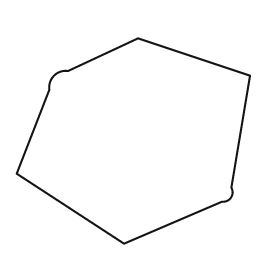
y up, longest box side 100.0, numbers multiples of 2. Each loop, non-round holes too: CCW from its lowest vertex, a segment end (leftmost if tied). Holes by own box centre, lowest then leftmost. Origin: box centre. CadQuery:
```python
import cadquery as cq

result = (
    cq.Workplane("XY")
    .moveTo(-4.0, -44.0)
    .lineTo(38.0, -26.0)
    .threePointArc((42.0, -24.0), (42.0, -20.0))
    .lineTo(50.0, 28.0)
    .lineTo(2.0, 44.0)
    .lineTo(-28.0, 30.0)
    .threePointArc((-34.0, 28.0), (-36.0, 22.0))
    .lineTo(-50.0, -14.0)
    .close()
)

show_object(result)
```